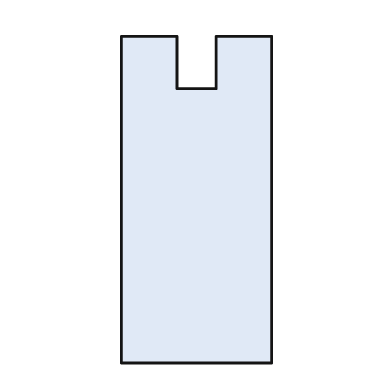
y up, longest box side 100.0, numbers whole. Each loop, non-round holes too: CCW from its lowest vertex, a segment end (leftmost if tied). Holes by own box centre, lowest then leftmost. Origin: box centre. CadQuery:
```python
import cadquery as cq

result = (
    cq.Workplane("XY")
    .moveTo(-23.0, -50.0)
    .lineTo(23.0, -50.0)
    .lineTo(23.0, 50.0)
    .lineTo(6.0, 50.0)
    .lineTo(6.0, 34.0)
    .lineTo(-6.0, 34.0)
    .lineTo(-6.0, 50.0)
    .lineTo(-23.0, 50.0)
    .close()
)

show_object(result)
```